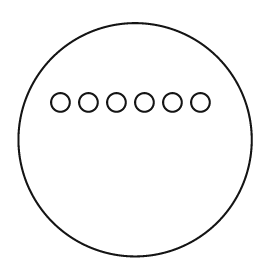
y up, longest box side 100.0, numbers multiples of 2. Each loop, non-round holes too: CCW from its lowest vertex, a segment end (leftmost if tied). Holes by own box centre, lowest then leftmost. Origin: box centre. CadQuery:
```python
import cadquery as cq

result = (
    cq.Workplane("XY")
    .moveTo(0.0, 0.0)
    .circle(50.0)
    .moveTo(-32.0, 16.0)
    .circle(4.0)
    .moveTo(-20.0, 16.0)
    .circle(4.0)
    .moveTo(-8.0, 16.0)
    .circle(4.0)
    .moveTo(4.0, 16.0)
    .circle(4.0)
    .moveTo(16.0, 16.0)
    .circle(4.0)
    .moveTo(28.0, 16.0)
    .circle(4.0)
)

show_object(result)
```